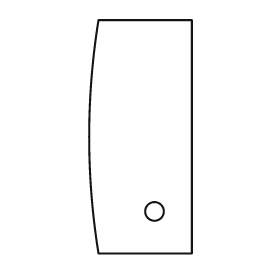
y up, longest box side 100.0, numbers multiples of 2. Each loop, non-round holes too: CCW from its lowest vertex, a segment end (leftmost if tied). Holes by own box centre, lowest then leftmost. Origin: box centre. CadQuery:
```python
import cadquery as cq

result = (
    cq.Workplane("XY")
    .moveTo(-18.0, -50.0)
    .lineTo(22.0, -50.0)
    .lineTo(22.0, 50.0)
    .lineTo(-18.0, 50.0)
    .threePointArc((-22.0, 0.0), (-18.0, -50.0))
    .close()
    .moveTo(6.0, -32.0)
    .circle(4.0)
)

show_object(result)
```